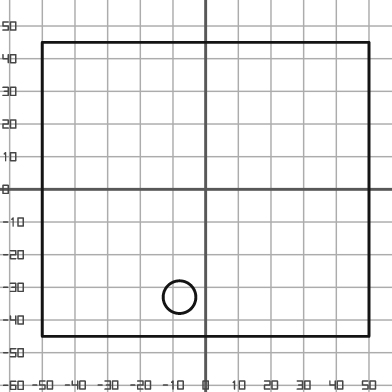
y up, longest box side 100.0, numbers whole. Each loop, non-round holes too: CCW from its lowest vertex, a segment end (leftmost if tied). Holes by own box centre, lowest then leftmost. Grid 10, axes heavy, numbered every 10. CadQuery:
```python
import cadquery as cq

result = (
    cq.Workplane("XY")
    .moveTo(-50.0, -45.0)
    .lineTo(50.0, -45.0)
    .lineTo(50.0, 45.0)
    .lineTo(-50.0, 45.0)
    .close()
    .moveTo(-8.0, -33.0)
    .circle(5.0)
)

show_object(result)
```